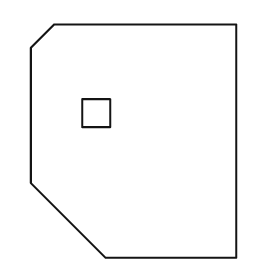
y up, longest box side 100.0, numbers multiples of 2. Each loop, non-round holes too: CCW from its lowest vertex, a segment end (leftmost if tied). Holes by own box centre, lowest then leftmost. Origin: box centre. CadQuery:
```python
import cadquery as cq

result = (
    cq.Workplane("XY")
    .moveTo(-12.0, -50.0)
    .lineTo(44.0, -50.0)
    .lineTo(44.0, 50.0)
    .lineTo(-34.0, 50.0)
    .lineTo(-44.0, 40.0)
    .lineTo(-44.0, -18.0)
    .close()
    .moveTo(-22.0, 6.0)
    .lineTo(-10.0, 6.0)
    .lineTo(-10.0, 18.0)
    .lineTo(-22.0, 18.0)
    .close()
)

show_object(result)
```